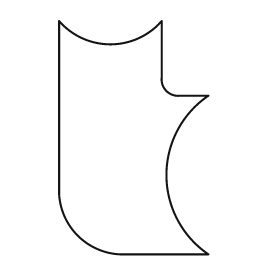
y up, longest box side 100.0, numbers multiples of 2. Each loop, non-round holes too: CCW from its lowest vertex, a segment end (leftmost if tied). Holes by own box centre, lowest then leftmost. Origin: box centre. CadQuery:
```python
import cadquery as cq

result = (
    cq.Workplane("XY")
    .moveTo(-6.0, -50.0)
    .lineTo(32.0, -50.0)
    .threePointArc((14.0, -16.0), (32.0, 18.0))
    .lineTo(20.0, 18.0)
    .threePointArc((14.0, 20.0), (12.0, 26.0))
    .lineTo(12.0, 50.0)
    .threePointArc((-10.0, 40.0), (-32.0, 50.0))
    .lineTo(-32.0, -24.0)
    .threePointArc((-24.0, -42.0), (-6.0, -50.0))
    .close()
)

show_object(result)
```